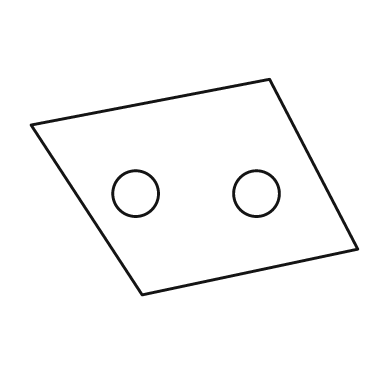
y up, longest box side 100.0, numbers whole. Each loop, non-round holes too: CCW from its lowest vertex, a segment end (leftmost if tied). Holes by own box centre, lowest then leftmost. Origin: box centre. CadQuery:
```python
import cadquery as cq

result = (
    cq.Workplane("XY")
    .moveTo(-16.0, -33.0)
    .lineTo(50.0, -19.0)
    .lineTo(23.0, 33.0)
    .lineTo(-50.0, 19.0)
    .close()
    .moveTo(-18.0, -2.0)
    .circle(7.0)
    .moveTo(19.0, -2.0)
    .circle(7.0)
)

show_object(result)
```